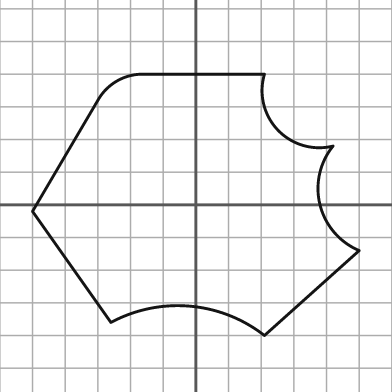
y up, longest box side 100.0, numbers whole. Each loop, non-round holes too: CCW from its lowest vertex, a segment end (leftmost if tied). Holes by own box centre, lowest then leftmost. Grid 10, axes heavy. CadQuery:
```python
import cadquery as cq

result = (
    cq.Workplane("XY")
    .moveTo(21.0, -40.0)
    .lineTo(50.0, -14.0)
    .threePointArc((38.0, 0.0), (42.0, 18.0))
    .threePointArc((25.0, 23.0), (21.0, 40.0))
    .lineTo(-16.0, 40.0)
    .threePointArc((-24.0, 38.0), (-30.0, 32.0))
    .lineTo(-50.0, -2.0)
    .lineTo(-26.0, -36.0)
    .threePointArc((-2.0, -31.0), (21.0, -40.0))
    .close()
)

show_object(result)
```